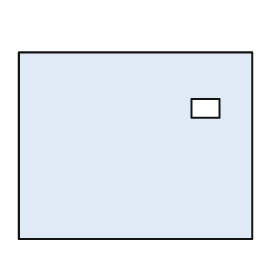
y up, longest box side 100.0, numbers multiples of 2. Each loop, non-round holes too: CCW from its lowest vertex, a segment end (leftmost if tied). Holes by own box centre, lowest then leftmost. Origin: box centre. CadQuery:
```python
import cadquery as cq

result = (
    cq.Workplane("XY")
    .moveTo(-50.0, -40.0)
    .lineTo(50.0, -40.0)
    .lineTo(50.0, 40.0)
    .lineTo(-50.0, 40.0)
    .close()
    .moveTo(24.0, 12.0)
    .lineTo(36.0, 12.0)
    .lineTo(36.0, 20.0)
    .lineTo(24.0, 20.0)
    .close()
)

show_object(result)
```